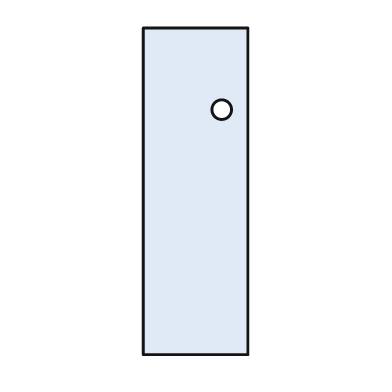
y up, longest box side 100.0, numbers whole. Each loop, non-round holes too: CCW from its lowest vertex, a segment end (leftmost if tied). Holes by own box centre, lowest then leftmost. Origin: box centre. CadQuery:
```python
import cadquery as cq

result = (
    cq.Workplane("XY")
    .moveTo(-16.0, -50.0)
    .lineTo(16.0, -50.0)
    .lineTo(16.0, 50.0)
    .lineTo(-16.0, 50.0)
    .close()
    .moveTo(8.0, 25.0)
    .circle(3.0)
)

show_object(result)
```